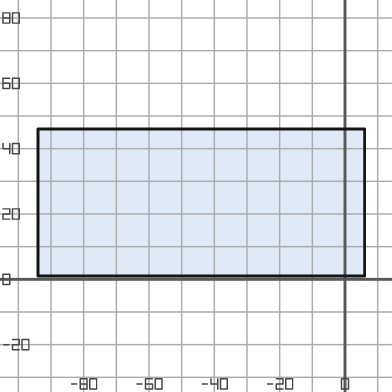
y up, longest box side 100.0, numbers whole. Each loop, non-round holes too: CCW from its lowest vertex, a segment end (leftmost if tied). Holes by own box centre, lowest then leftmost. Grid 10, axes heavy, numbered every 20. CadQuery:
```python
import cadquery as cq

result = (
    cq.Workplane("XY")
    .moveTo(-94.0, 1.0)
    .lineTo(6.0, 1.0)
    .lineTo(6.0, 46.0)
    .lineTo(-94.0, 46.0)
    .close()
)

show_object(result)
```